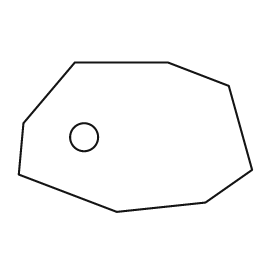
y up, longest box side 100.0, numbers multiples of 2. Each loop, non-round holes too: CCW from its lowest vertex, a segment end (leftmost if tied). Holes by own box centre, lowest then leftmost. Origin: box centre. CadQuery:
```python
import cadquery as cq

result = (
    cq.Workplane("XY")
    .moveTo(-8.0, -32.0)
    .lineTo(30.0, -28.0)
    .lineTo(50.0, -14.0)
    .lineTo(40.0, 22.0)
    .lineTo(14.0, 32.0)
    .lineTo(-26.0, 32.0)
    .lineTo(-48.0, 6.0)
    .lineTo(-50.0, -16.0)
    .close()
    .moveTo(-22.0, 0.0)
    .circle(6.0)
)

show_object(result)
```